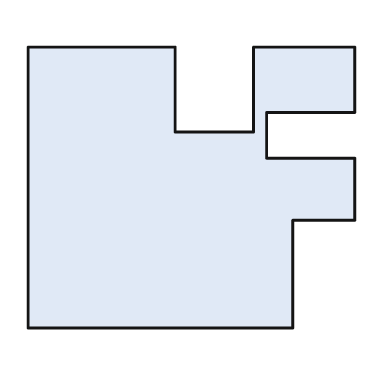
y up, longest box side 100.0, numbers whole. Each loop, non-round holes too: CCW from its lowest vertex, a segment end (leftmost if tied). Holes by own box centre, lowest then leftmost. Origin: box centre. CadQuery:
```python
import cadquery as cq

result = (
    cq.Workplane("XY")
    .moveTo(-50.0, -43.0)
    .lineTo(31.0, -43.0)
    .lineTo(31.0, -10.0)
    .lineTo(50.0, -10.0)
    .lineTo(50.0, 9.0)
    .lineTo(23.0, 9.0)
    .lineTo(23.0, 23.0)
    .lineTo(50.0, 23.0)
    .lineTo(50.0, 43.0)
    .lineTo(19.0, 43.0)
    .lineTo(19.0, 17.0)
    .lineTo(-5.0, 17.0)
    .lineTo(-5.0, 43.0)
    .lineTo(-50.0, 43.0)
    .close()
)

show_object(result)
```